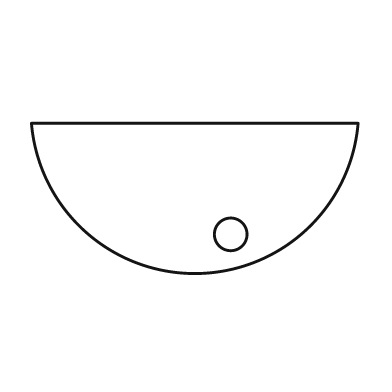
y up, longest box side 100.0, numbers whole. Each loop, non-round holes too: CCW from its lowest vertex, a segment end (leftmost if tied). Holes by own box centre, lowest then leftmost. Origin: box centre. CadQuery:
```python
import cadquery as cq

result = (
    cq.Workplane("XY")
    .moveTo(-50.0, 23.0)
    .threePointArc((0.0, -23.0), (50.0, 23.0))
    .close()
    .moveTo(11.0, -11.0)
    .circle(5.0)
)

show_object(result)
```